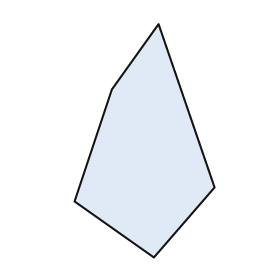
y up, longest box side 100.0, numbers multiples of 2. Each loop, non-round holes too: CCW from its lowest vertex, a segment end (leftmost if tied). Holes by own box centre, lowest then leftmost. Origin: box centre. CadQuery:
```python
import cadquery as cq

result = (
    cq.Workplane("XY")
    .moveTo(4.0, -50.0)
    .lineTo(30.0, -20.0)
    .lineTo(6.0, 50.0)
    .lineTo(-14.0, 22.0)
    .lineTo(-30.0, -26.0)
    .close()
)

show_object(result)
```